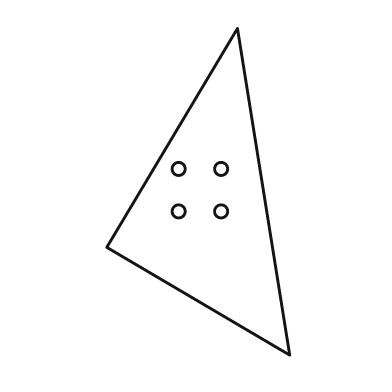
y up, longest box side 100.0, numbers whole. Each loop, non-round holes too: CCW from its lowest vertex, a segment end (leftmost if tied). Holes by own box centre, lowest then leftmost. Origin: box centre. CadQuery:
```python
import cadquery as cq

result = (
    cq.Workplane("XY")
    .moveTo(28.0, -50.0)
    .lineTo(12.0, 50.0)
    .lineTo(-28.0, -17.0)
    .close()
    .moveTo(-6.0, -6.0)
    .circle(2.0)
    .moveTo(7.0, -6.0)
    .circle(2.0)
    .moveTo(-6.0, 7.0)
    .circle(2.0)
    .moveTo(7.0, 7.0)
    .circle(2.0)
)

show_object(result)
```